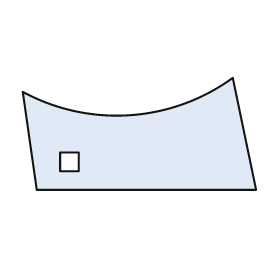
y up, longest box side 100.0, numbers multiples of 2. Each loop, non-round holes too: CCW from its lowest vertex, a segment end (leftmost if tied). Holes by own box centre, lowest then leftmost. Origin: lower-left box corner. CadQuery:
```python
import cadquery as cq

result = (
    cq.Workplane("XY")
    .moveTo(6.0, 0.0)
    .lineTo(100.0, 0.0)
    .lineTo(90.0, 48.0)
    .threePointArc((46.0, 32.0), (0.0, 42.0))
    .close()
    .moveTo(16.0, 8.0)
    .lineTo(24.0, 8.0)
    .lineTo(24.0, 16.0)
    .lineTo(16.0, 16.0)
    .close()
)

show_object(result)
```